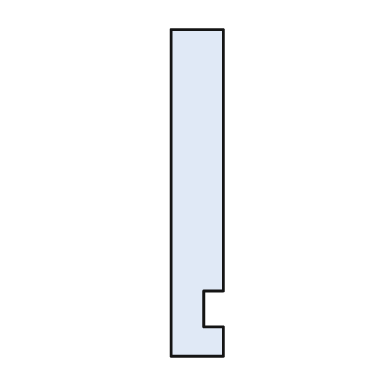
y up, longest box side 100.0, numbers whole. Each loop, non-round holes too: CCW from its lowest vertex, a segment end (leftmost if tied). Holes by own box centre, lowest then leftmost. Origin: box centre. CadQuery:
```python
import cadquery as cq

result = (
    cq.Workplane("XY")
    .moveTo(-8.0, -50.0)
    .lineTo(8.0, -50.0)
    .lineTo(8.0, -41.0)
    .lineTo(2.0, -41.0)
    .lineTo(2.0, -30.0)
    .lineTo(8.0, -30.0)
    .lineTo(8.0, 50.0)
    .lineTo(-8.0, 50.0)
    .close()
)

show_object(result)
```